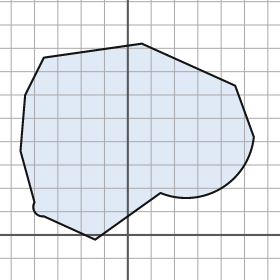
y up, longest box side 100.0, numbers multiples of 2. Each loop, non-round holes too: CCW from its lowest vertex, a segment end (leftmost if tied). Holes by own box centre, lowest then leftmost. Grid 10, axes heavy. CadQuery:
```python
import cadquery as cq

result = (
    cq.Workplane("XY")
    .moveTo(-14.0, -2.0)
    .lineTo(14.0, 18.0)
    .threePointArc((40.0, 20.0), (54.0, 42.0))
    .lineTo(46.0, 64.0)
    .lineTo(6.0, 82.0)
    .lineTo(-36.0, 76.0)
    .lineTo(-44.0, 60.0)
    .lineTo(-46.0, 36.0)
    .lineTo(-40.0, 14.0)
    .threePointArc((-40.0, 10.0), (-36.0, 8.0))
    .close()
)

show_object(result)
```